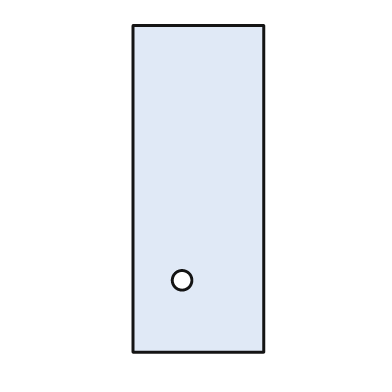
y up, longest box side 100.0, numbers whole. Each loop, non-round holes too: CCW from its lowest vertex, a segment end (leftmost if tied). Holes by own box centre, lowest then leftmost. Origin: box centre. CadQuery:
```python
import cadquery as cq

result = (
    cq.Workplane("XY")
    .moveTo(-20.0, -50.0)
    .lineTo(20.0, -50.0)
    .lineTo(20.0, 50.0)
    .lineTo(-20.0, 50.0)
    .close()
    .moveTo(-5.0, -28.0)
    .circle(3.0)
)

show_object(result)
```